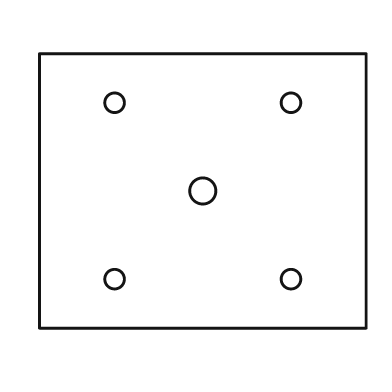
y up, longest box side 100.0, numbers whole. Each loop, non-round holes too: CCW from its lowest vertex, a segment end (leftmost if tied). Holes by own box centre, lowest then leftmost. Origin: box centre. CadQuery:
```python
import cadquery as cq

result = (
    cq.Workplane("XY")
    .moveTo(-50.0, -42.0)
    .lineTo(50.0, -42.0)
    .lineTo(50.0, 42.0)
    .lineTo(-50.0, 42.0)
    .close()
    .moveTo(-27.0, -27.0)
    .circle(3.0)
    .moveTo(27.0, -27.0)
    .circle(3.0)
    .moveTo(0.0, 0.0)
    .circle(4.0)
    .moveTo(-27.0, 27.0)
    .circle(3.0)
    .moveTo(27.0, 27.0)
    .circle(3.0)
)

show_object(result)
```